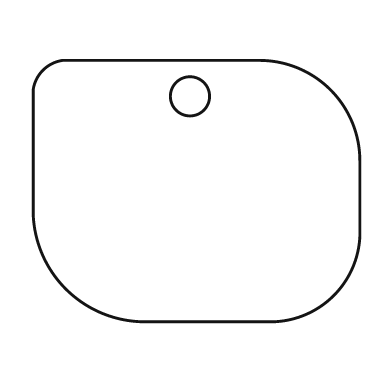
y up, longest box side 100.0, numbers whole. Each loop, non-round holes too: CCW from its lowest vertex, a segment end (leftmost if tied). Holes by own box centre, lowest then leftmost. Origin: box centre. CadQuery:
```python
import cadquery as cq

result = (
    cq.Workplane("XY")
    .moveTo(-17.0, -40.0)
    .lineTo(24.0, -40.0)
    .threePointArc((42.0, -32.0), (50.0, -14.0))
    .lineTo(50.0, 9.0)
    .threePointArc((41.0, 31.0), (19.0, 40.0))
    .lineTo(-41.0, 40.0)
    .threePointArc((-47.0, 37.0), (-50.0, 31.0))
    .lineTo(-50.0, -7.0)
    .threePointArc((-40.0, -30.0), (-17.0, -40.0))
    .close()
    .moveTo(-2.0, 29.0)
    .circle(6.0)
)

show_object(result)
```